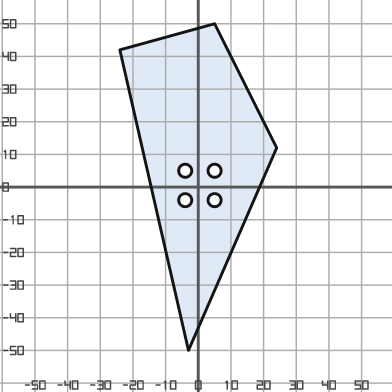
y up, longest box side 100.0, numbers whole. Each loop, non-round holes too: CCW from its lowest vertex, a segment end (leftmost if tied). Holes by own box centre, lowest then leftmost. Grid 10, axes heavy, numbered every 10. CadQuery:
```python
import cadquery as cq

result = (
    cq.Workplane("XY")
    .moveTo(-3.0, -50.0)
    .lineTo(24.0, 12.0)
    .lineTo(5.0, 50.0)
    .lineTo(-24.0, 42.0)
    .close()
    .moveTo(-4.0, -4.0)
    .circle(2.0)
    .moveTo(5.0, -4.0)
    .circle(2.0)
    .moveTo(-4.0, 5.0)
    .circle(2.0)
    .moveTo(5.0, 5.0)
    .circle(2.0)
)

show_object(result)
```